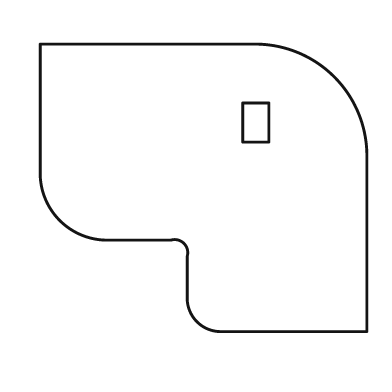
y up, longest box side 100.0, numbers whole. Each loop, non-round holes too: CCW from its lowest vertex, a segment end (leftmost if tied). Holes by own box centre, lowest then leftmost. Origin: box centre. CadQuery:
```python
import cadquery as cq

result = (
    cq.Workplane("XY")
    .moveTo(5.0, -44.0)
    .lineTo(50.0, -44.0)
    .lineTo(50.0, 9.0)
    .threePointArc((40.0, 34.0), (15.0, 44.0))
    .lineTo(-50.0, 44.0)
    .lineTo(-50.0, 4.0)
    .threePointArc((-44.0, -10.0), (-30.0, -16.0))
    .lineTo(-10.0, -16.0)
    .threePointArc((-6.0, -17.0), (-5.0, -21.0))
    .lineTo(-5.0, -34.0)
    .threePointArc((-2.0, -41.0), (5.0, -44.0))
    .close()
    .moveTo(12.0, 14.0)
    .lineTo(20.0, 14.0)
    .lineTo(20.0, 26.0)
    .lineTo(12.0, 26.0)
    .close()
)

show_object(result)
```